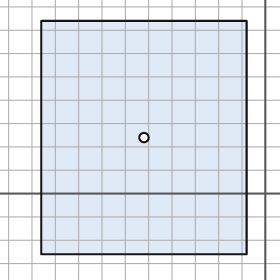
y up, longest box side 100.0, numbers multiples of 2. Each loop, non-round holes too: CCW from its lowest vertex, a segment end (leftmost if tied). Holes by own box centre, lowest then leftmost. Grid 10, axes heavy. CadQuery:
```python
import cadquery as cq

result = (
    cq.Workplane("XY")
    .moveTo(-96.0, -26.0)
    .lineTo(-8.0, -26.0)
    .lineTo(-8.0, 74.0)
    .lineTo(-96.0, 74.0)
    .close()
    .moveTo(-52.0, 24.0)
    .circle(2.0)
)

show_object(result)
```